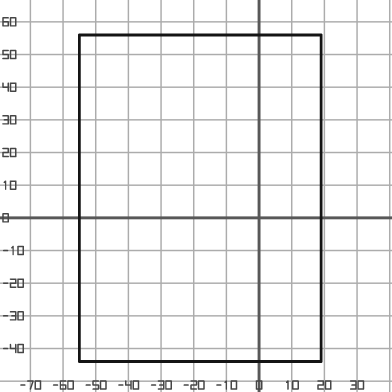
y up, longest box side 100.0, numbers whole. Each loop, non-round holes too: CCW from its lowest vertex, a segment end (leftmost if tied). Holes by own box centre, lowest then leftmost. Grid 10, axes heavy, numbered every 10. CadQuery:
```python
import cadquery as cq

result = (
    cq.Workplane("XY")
    .moveTo(-55.0, -44.0)
    .lineTo(19.0, -44.0)
    .lineTo(19.0, 56.0)
    .lineTo(-55.0, 56.0)
    .close()
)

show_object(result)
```